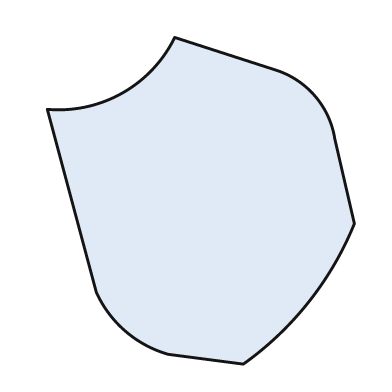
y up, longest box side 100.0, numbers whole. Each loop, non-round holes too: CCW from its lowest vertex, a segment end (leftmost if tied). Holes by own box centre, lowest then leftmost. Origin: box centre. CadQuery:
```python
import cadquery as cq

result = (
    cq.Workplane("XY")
    .moveTo(13.0, -50.0)
    .threePointArc((33.0, -31.0), (47.0, -7.0))
    .lineTo(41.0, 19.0)
    .threePointArc((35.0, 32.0), (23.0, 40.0))
    .lineTo(-8.0, 50.0)
    .threePointArc((-24.0, 33.0), (-47.0, 28.0))
    .lineTo(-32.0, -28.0)
    .threePointArc((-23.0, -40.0), (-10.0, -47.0))
    .close()
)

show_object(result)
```